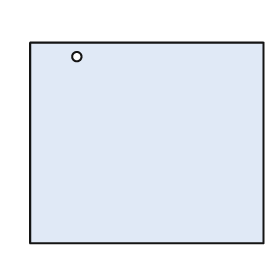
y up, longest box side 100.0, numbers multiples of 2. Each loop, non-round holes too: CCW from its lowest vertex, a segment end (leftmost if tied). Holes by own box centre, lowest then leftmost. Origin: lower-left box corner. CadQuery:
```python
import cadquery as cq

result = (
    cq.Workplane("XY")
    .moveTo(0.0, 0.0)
    .lineTo(100.0, 0.0)
    .lineTo(100.0, 86.0)
    .lineTo(0.0, 86.0)
    .close()
    .moveTo(20.0, 80.0)
    .circle(2.0)
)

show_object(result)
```